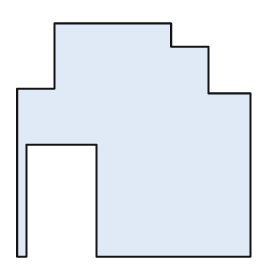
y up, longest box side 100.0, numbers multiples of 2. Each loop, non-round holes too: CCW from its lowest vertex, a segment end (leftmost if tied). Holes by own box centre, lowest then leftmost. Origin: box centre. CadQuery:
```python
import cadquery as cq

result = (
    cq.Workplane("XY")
    .moveTo(-50.0, -50.0)
    .lineTo(-46.0, -50.0)
    .lineTo(-46.0, -2.0)
    .lineTo(-16.0, -2.0)
    .lineTo(-16.0, -50.0)
    .lineTo(50.0, -50.0)
    .lineTo(50.0, 20.0)
    .lineTo(32.0, 20.0)
    .lineTo(32.0, 40.0)
    .lineTo(16.0, 40.0)
    .lineTo(16.0, 50.0)
    .lineTo(-34.0, 50.0)
    .lineTo(-34.0, 22.0)
    .lineTo(-50.0, 22.0)
    .close()
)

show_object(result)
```